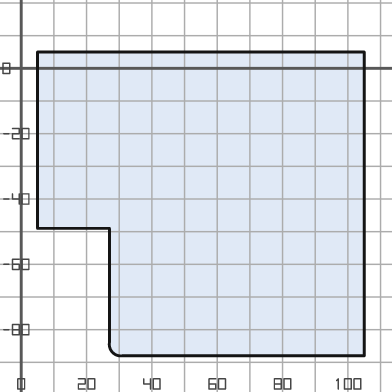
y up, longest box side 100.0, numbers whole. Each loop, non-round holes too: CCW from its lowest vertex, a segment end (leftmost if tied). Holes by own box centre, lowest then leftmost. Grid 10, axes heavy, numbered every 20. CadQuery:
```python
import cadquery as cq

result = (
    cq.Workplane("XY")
    .moveTo(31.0, -88.0)
    .lineTo(105.0, -88.0)
    .lineTo(105.0, 5.0)
    .lineTo(5.0, 5.0)
    .lineTo(5.0, -49.0)
    .lineTo(27.0, -49.0)
    .lineTo(27.0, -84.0)
    .threePointArc((28.0, -87.0), (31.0, -88.0))
    .close()
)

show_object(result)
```